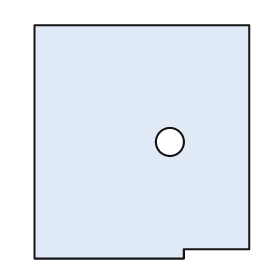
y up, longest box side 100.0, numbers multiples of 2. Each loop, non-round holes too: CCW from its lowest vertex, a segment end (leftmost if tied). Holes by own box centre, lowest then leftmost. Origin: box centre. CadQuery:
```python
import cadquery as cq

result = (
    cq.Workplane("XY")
    .moveTo(-46.0, -50.0)
    .lineTo(18.0, -50.0)
    .lineTo(18.0, -46.0)
    .lineTo(46.0, -46.0)
    .lineTo(46.0, 50.0)
    .lineTo(-46.0, 50.0)
    .close()
    .moveTo(12.0, 0.0)
    .circle(6.0)
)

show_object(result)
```